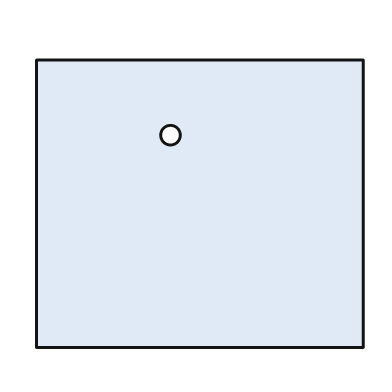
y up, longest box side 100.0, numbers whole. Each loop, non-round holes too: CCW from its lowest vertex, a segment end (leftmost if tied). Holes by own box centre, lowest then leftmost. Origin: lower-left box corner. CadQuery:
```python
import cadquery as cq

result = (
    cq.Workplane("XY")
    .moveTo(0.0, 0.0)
    .lineTo(100.0, 0.0)
    .lineTo(100.0, 88.0)
    .lineTo(0.0, 88.0)
    .close()
    .moveTo(41.0, 65.0)
    .circle(3.0)
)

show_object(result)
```